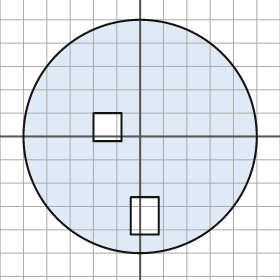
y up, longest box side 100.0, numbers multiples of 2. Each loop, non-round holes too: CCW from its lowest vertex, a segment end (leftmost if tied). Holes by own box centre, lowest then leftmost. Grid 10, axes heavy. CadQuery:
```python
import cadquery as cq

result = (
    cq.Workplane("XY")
    .moveTo(0.0, 0.0)
    .circle(50.0)
    .moveTo(-4.0, -42.0)
    .lineTo(8.0, -42.0)
    .lineTo(8.0, -26.0)
    .lineTo(-4.0, -26.0)
    .close()
    .moveTo(-20.0, -2.0)
    .lineTo(-8.0, -2.0)
    .lineTo(-8.0, 10.0)
    .lineTo(-20.0, 10.0)
    .close()
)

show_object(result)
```